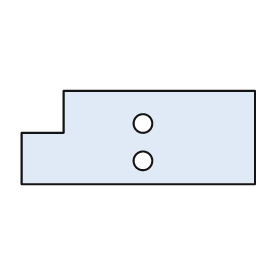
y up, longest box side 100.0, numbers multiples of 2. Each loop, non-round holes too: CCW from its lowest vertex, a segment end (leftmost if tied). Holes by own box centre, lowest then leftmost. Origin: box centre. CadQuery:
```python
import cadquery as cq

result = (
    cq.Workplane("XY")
    .moveTo(-50.0, -20.0)
    .lineTo(50.0, -20.0)
    .lineTo(50.0, 20.0)
    .lineTo(-32.0, 20.0)
    .lineTo(-32.0, 2.0)
    .lineTo(-50.0, 2.0)
    .close()
    .moveTo(2.0, -10.0)
    .circle(4.0)
    .moveTo(2.0, 6.0)
    .circle(4.0)
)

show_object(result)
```